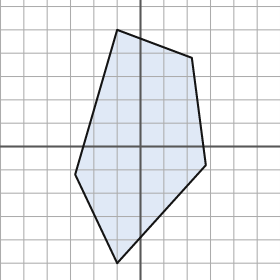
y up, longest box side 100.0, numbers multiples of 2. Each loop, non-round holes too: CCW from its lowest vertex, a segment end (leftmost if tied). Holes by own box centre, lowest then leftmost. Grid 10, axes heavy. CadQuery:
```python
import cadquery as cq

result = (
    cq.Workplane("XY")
    .moveTo(-10.0, -50.0)
    .lineTo(28.0, -8.0)
    .lineTo(22.0, 38.0)
    .lineTo(-10.0, 50.0)
    .lineTo(-28.0, -12.0)
    .close()
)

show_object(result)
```